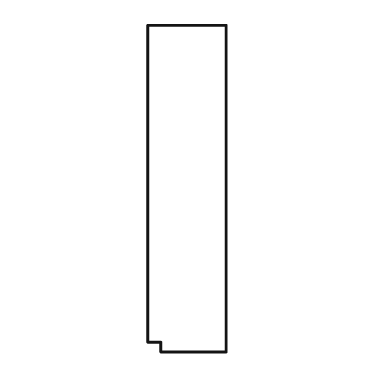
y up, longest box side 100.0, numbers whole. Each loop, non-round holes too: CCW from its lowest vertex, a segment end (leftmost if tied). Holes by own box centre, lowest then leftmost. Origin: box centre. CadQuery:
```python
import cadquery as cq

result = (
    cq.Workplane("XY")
    .moveTo(-8.0, -50.0)
    .lineTo(12.0, -50.0)
    .lineTo(12.0, 50.0)
    .lineTo(-12.0, 50.0)
    .lineTo(-12.0, -47.0)
    .lineTo(-8.0, -47.0)
    .close()
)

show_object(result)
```